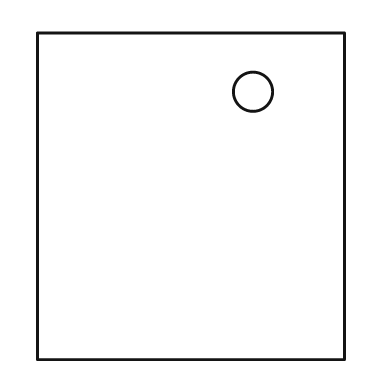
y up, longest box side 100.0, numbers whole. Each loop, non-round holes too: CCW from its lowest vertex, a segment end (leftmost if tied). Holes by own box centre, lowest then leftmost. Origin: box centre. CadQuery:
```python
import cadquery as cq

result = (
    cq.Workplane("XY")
    .moveTo(-47.0, -50.0)
    .lineTo(47.0, -50.0)
    .lineTo(47.0, 50.0)
    .lineTo(-47.0, 50.0)
    .close()
    .moveTo(19.0, 32.0)
    .circle(6.0)
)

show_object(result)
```